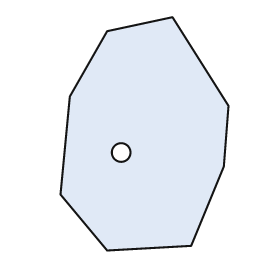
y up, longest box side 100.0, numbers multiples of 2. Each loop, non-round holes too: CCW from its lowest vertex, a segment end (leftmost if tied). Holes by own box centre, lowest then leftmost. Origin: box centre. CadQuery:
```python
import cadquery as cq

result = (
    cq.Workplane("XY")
    .moveTo(-16.0, -50.0)
    .lineTo(20.0, -48.0)
    .lineTo(34.0, -14.0)
    .lineTo(36.0, 12.0)
    .lineTo(12.0, 50.0)
    .lineTo(-16.0, 44.0)
    .lineTo(-32.0, 16.0)
    .lineTo(-36.0, -26.0)
    .close()
    .moveTo(-10.0, -8.0)
    .circle(4.0)
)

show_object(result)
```